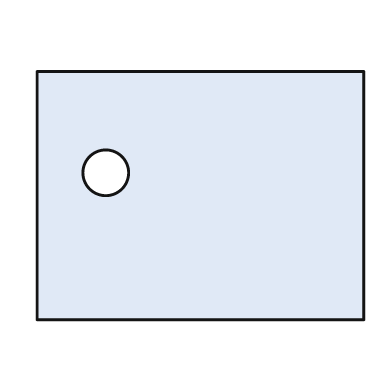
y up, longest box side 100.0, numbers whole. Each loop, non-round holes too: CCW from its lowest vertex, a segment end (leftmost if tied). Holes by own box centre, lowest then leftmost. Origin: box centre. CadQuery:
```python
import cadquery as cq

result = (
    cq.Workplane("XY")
    .moveTo(-50.0, -38.0)
    .lineTo(50.0, -38.0)
    .lineTo(50.0, 38.0)
    .lineTo(-50.0, 38.0)
    .close()
    .moveTo(-29.0, 7.0)
    .circle(7.0)
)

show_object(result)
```